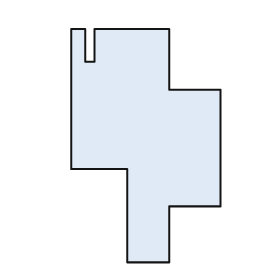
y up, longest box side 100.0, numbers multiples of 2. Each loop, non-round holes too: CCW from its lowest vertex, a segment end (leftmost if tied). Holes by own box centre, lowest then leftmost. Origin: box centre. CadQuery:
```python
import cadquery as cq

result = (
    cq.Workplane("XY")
    .moveTo(-8.0, -50.0)
    .lineTo(10.0, -50.0)
    .lineTo(10.0, -26.0)
    .lineTo(32.0, -26.0)
    .lineTo(32.0, 24.0)
    .lineTo(10.0, 24.0)
    .lineTo(10.0, 50.0)
    .lineTo(-22.0, 50.0)
    .lineTo(-22.0, 36.0)
    .lineTo(-26.0, 36.0)
    .lineTo(-26.0, 50.0)
    .lineTo(-32.0, 50.0)
    .lineTo(-32.0, -10.0)
    .lineTo(-8.0, -10.0)
    .close()
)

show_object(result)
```